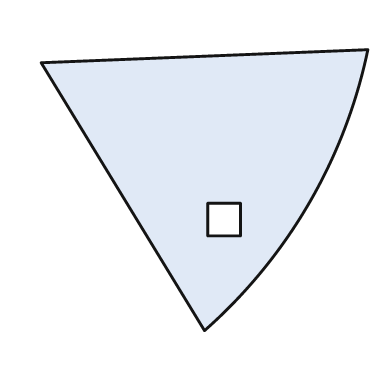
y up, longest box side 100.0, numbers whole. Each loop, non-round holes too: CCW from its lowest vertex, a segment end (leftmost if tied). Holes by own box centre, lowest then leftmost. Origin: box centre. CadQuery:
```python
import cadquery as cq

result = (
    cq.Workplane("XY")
    .moveTo(0.0, -43.0)
    .threePointArc((32.0, -4.0), (50.0, 43.0))
    .lineTo(-50.0, 39.0)
    .close()
    .moveTo(1.0, -14.0)
    .lineTo(11.0, -14.0)
    .lineTo(11.0, -4.0)
    .lineTo(1.0, -4.0)
    .close()
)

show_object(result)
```